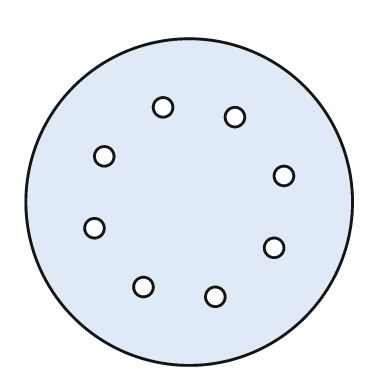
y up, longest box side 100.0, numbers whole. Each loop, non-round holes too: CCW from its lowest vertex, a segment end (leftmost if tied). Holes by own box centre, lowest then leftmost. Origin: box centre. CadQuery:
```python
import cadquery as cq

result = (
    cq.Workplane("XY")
    .moveTo(0.0, 0.0)
    .circle(50.0)
    .moveTo(8.0, -29.0)
    .circle(3.0)
    .moveTo(-14.0, -26.0)
    .circle(3.0)
    .moveTo(26.0, -14.0)
    .circle(3.0)
    .moveTo(-29.0, -8.0)
    .circle(3.0)
    .moveTo(29.0, 8.0)
    .circle(3.0)
    .moveTo(-26.0, 14.0)
    .circle(3.0)
    .moveTo(14.0, 26.0)
    .circle(3.0)
    .moveTo(-8.0, 29.0)
    .circle(3.0)
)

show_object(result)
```